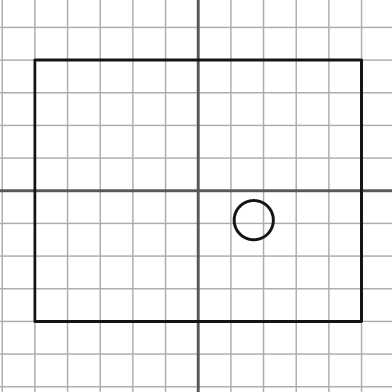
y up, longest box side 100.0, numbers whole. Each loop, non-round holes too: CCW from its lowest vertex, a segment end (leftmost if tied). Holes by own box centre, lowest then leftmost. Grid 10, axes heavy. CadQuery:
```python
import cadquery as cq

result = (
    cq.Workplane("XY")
    .moveTo(-50.0, -40.0)
    .lineTo(50.0, -40.0)
    .lineTo(50.0, 40.0)
    .lineTo(-50.0, 40.0)
    .close()
    .moveTo(17.0, -9.0)
    .circle(6.0)
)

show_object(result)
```